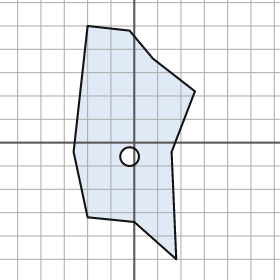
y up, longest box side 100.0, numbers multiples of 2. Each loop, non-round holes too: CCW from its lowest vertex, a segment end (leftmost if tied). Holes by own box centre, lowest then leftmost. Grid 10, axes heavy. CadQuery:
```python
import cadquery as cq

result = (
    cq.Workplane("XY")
    .moveTo(18.0, -50.0)
    .lineTo(16.0, -4.0)
    .lineTo(26.0, 22.0)
    .lineTo(8.0, 36.0)
    .lineTo(-2.0, 48.0)
    .lineTo(-20.0, 50.0)
    .lineTo(-26.0, -4.0)
    .lineTo(-20.0, -32.0)
    .lineTo(0.0, -34.0)
    .close()
    .moveTo(-2.0, -6.0)
    .circle(4.0)
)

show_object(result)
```